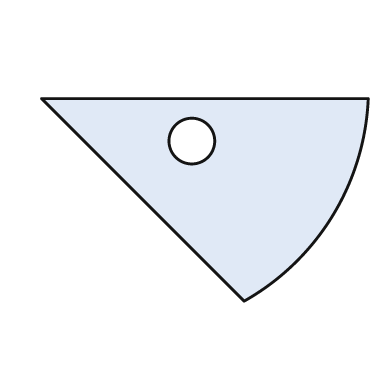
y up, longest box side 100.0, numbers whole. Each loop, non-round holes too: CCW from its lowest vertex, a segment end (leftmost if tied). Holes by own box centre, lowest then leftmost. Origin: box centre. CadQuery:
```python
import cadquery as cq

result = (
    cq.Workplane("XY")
    .moveTo(12.0, -31.0)
    .threePointArc((39.0, -5.0), (50.0, 31.0))
    .lineTo(-50.0, 31.0)
    .close()
    .moveTo(-4.0, 18.0)
    .circle(7.0)
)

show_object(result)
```